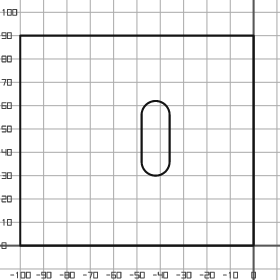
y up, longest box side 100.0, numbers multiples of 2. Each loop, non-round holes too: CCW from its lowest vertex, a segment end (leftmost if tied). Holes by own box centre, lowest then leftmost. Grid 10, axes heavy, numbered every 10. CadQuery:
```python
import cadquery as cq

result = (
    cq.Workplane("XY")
    .moveTo(-100.0, 0.0)
    .lineTo(0.0, 0.0)
    .lineTo(0.0, 90.0)
    .lineTo(-100.0, 90.0)
    .close()
    .moveTo(-48.0, 36.0)
    .threePointArc((-42.0, 30.0), (-36.0, 36.0))
    .lineTo(-36.0, 56.0)
    .threePointArc((-42.0, 62.0), (-48.0, 56.0))
    .close()
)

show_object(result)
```